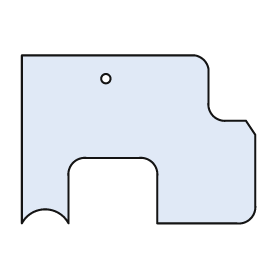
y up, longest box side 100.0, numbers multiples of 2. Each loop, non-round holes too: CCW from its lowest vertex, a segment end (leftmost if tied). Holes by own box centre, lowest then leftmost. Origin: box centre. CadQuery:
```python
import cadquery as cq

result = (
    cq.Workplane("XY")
    .moveTo(-50.0, -36.0)
    .threePointArc((-40.0, -30.0), (-30.0, -36.0))
    .lineTo(-30.0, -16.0)
    .threePointArc((-28.0, -10.0), (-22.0, -8.0))
    .lineTo(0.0, -8.0)
    .threePointArc((6.0, -10.0), (8.0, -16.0))
    .lineTo(8.0, -36.0)
    .lineTo(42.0, -36.0)
    .threePointArc((48.0, -34.0), (50.0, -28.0))
    .lineTo(50.0, 2.0)
    .lineTo(46.0, 8.0)
    .lineTo(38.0, 8.0)
    .threePointArc((32.0, 10.0), (30.0, 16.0))
    .lineTo(30.0, 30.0)
    .threePointArc((28.0, 34.0), (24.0, 36.0))
    .lineTo(-50.0, 36.0)
    .close()
    .moveTo(-14.0, 26.0)
    .circle(2.0)
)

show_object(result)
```